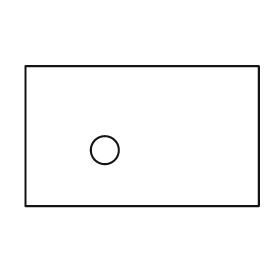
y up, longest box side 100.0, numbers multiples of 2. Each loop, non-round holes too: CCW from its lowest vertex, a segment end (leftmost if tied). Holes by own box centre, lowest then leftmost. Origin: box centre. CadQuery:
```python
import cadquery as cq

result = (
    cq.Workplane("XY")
    .moveTo(-50.0, -30.0)
    .lineTo(50.0, -30.0)
    .lineTo(50.0, 30.0)
    .lineTo(-50.0, 30.0)
    .close()
    .moveTo(-16.0, -6.0)
    .circle(6.0)
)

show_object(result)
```